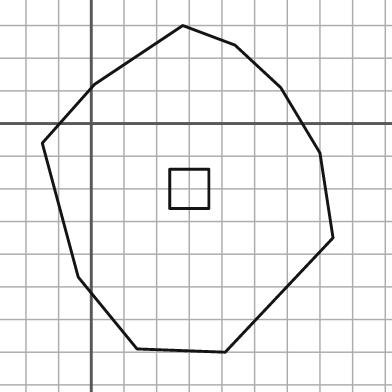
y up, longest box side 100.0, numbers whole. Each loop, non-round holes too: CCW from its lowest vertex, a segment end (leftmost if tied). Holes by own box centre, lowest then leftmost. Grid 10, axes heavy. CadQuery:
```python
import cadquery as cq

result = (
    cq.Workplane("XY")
    .moveTo(41.0, -70.0)
    .lineTo(74.0, -35.0)
    .lineTo(70.0, -9.0)
    .lineTo(58.0, 11.0)
    .lineTo(44.0, 24.0)
    .lineTo(28.0, 30.0)
    .lineTo(1.0, 12.0)
    .lineTo(-15.0, -6.0)
    .lineTo(-4.0, -47.0)
    .lineTo(14.0, -69.0)
    .close()
    .moveTo(24.0, -26.0)
    .lineTo(36.0, -26.0)
    .lineTo(36.0, -14.0)
    .lineTo(24.0, -14.0)
    .close()
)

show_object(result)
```